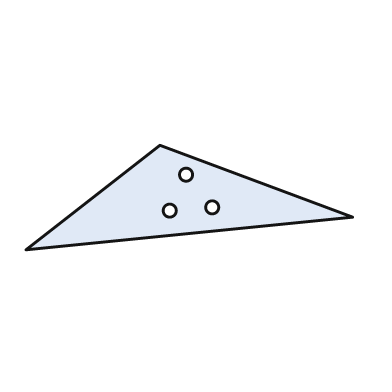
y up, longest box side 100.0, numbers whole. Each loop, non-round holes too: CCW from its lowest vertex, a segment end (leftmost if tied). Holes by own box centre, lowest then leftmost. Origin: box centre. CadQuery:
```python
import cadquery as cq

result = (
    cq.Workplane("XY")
    .moveTo(-50.0, -16.0)
    .lineTo(50.0, -6.0)
    .lineTo(-9.0, 16.0)
    .close()
    .moveTo(-6.0, -4.0)
    .circle(2.0)
    .moveTo(7.0, -3.0)
    .circle(2.0)
    .moveTo(-1.0, 7.0)
    .circle(2.0)
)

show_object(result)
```